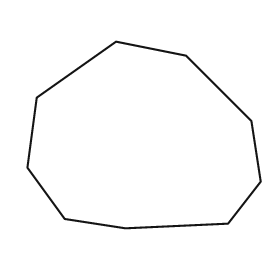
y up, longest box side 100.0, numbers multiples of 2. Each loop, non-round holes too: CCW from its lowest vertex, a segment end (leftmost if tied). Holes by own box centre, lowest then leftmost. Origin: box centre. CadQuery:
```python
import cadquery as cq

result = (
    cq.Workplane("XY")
    .moveTo(-8.0, -40.0)
    .lineTo(36.0, -38.0)
    .lineTo(50.0, -20.0)
    .lineTo(46.0, 6.0)
    .lineTo(18.0, 34.0)
    .lineTo(-12.0, 40.0)
    .lineTo(-46.0, 16.0)
    .lineTo(-50.0, -14.0)
    .lineTo(-34.0, -36.0)
    .close()
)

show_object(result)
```